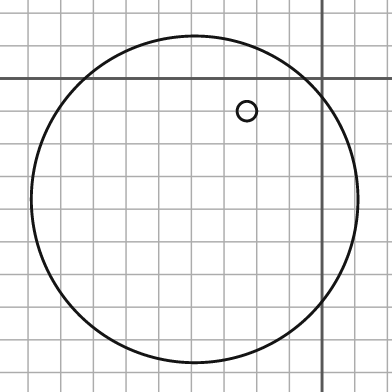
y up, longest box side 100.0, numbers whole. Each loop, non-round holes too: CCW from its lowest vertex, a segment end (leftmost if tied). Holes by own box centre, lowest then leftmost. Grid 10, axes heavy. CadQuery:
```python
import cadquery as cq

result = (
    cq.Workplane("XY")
    .moveTo(-39.0, -37.0)
    .circle(50.0)
    .moveTo(-23.0, -10.0)
    .circle(3.0)
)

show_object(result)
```